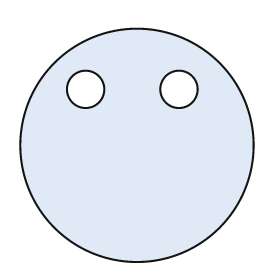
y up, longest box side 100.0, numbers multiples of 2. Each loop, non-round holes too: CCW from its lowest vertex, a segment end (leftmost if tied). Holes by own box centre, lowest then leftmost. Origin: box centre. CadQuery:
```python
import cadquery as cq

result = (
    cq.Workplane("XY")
    .moveTo(0.0, 0.0)
    .circle(50.0)
    .moveTo(-22.0, 24.0)
    .circle(8.0)
    .moveTo(18.0, 24.0)
    .circle(8.0)
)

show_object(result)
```